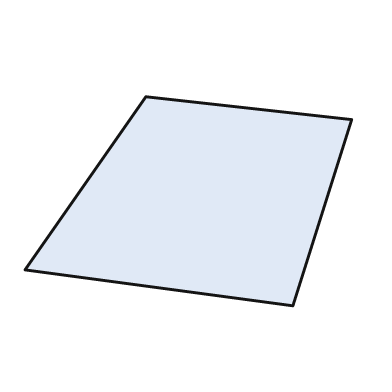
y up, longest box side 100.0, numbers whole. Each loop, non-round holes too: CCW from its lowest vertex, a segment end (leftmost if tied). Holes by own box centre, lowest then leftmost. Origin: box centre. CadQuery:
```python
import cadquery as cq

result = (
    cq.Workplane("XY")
    .moveTo(32.0, -32.0)
    .lineTo(50.0, 25.0)
    .lineTo(-13.0, 32.0)
    .lineTo(-50.0, -21.0)
    .close()
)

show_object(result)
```